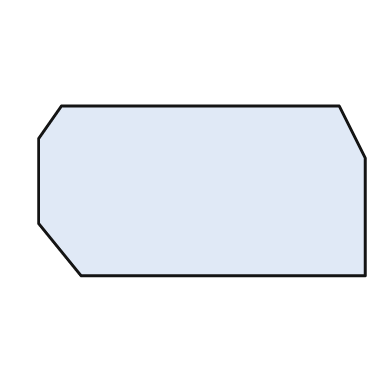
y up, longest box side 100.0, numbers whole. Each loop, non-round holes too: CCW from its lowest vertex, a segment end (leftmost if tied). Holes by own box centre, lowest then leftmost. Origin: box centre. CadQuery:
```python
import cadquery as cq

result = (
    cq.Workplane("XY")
    .moveTo(-37.0, -26.0)
    .lineTo(50.0, -26.0)
    .lineTo(50.0, 10.0)
    .lineTo(42.0, 26.0)
    .lineTo(-43.0, 26.0)
    .lineTo(-50.0, 16.0)
    .lineTo(-50.0, -10.0)
    .close()
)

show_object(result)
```